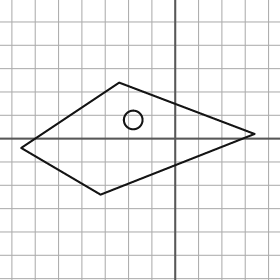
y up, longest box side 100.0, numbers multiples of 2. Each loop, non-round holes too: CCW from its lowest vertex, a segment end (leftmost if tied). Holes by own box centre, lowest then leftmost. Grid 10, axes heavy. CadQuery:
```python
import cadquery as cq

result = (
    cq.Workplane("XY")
    .moveTo(-32.0, -24.0)
    .lineTo(34.0, 2.0)
    .lineTo(-24.0, 24.0)
    .lineTo(-66.0, -4.0)
    .close()
    .moveTo(-18.0, 8.0)
    .circle(4.0)
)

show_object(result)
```